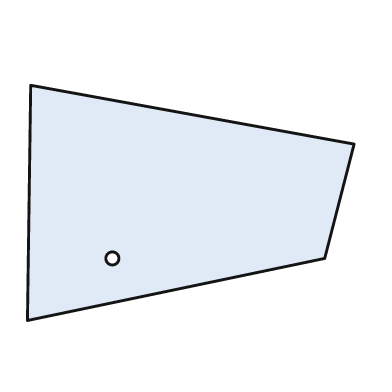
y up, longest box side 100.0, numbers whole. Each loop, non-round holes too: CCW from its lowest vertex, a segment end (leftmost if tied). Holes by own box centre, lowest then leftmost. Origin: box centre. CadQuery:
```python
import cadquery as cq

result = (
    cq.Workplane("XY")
    .moveTo(-50.0, -36.0)
    .lineTo(41.0, -17.0)
    .lineTo(50.0, 18.0)
    .lineTo(-49.0, 36.0)
    .close()
    .moveTo(-24.0, -17.0)
    .circle(2.0)
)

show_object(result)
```